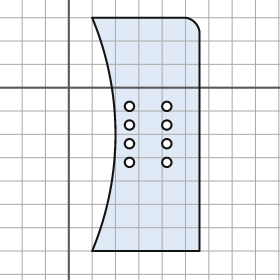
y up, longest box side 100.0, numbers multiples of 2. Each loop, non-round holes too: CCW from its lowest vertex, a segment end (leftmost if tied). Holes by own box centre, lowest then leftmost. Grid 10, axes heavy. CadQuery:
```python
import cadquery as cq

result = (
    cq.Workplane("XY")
    .moveTo(10.0, -70.0)
    .lineTo(56.0, -70.0)
    .lineTo(56.0, 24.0)
    .threePointArc((54.0, 28.0), (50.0, 30.0))
    .lineTo(10.0, 30.0)
    .threePointArc((20.0, -20.0), (10.0, -70.0))
    .close()
    .moveTo(26.0, -32.0)
    .circle(2.0)
    .moveTo(42.0, -32.0)
    .circle(2.0)
    .moveTo(26.0, -24.0)
    .circle(2.0)
    .moveTo(42.0, -24.0)
    .circle(2.0)
    .moveTo(26.0, -16.0)
    .circle(2.0)
    .moveTo(42.0, -16.0)
    .circle(2.0)
    .moveTo(26.0, -8.0)
    .circle(2.0)
    .moveTo(42.0, -8.0)
    .circle(2.0)
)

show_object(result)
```